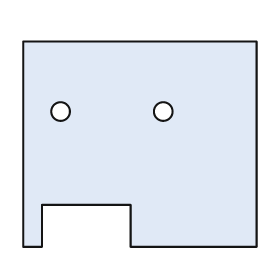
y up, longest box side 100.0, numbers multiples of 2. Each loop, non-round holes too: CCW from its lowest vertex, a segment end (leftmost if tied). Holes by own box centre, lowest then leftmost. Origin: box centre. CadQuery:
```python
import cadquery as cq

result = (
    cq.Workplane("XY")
    .moveTo(-50.0, -44.0)
    .lineTo(-42.0, -44.0)
    .lineTo(-42.0, -26.0)
    .lineTo(-4.0, -26.0)
    .lineTo(-4.0, -44.0)
    .lineTo(50.0, -44.0)
    .lineTo(50.0, 44.0)
    .lineTo(-50.0, 44.0)
    .close()
    .moveTo(-34.0, 14.0)
    .circle(4.0)
    .moveTo(10.0, 14.0)
    .circle(4.0)
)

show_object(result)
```